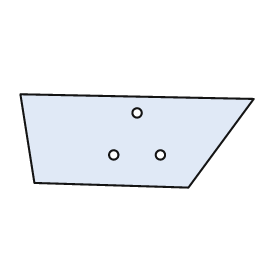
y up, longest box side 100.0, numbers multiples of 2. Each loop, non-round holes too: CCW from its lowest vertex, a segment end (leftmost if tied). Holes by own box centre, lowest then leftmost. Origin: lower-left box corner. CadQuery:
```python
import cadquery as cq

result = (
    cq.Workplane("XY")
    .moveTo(72.0, 0.0)
    .lineTo(100.0, 38.0)
    .lineTo(0.0, 40.0)
    .lineTo(6.0, 2.0)
    .close()
    .moveTo(40.0, 14.0)
    .circle(2.0)
    .moveTo(60.0, 14.0)
    .circle(2.0)
    .moveTo(50.0, 32.0)
    .circle(2.0)
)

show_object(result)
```